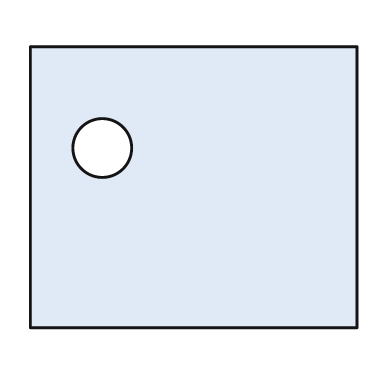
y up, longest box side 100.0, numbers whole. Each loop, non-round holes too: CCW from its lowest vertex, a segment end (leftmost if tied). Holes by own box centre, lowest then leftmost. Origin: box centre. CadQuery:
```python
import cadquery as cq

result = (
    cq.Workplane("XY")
    .moveTo(-50.0, -43.0)
    .lineTo(50.0, -43.0)
    .lineTo(50.0, 43.0)
    .lineTo(-50.0, 43.0)
    .close()
    .moveTo(-28.0, 12.0)
    .circle(9.0)
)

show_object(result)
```